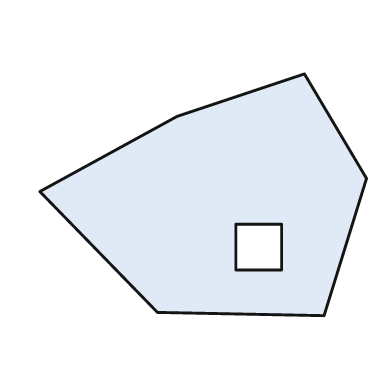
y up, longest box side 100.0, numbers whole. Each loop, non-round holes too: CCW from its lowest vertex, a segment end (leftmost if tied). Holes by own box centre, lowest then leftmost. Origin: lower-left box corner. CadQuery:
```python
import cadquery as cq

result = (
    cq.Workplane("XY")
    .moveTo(87.0, 0.0)
    .lineTo(100.0, 42.0)
    .lineTo(81.0, 74.0)
    .lineTo(42.0, 61.0)
    .lineTo(0.0, 38.0)
    .lineTo(36.0, 1.0)
    .close()
    .moveTo(60.0, 14.0)
    .lineTo(74.0, 14.0)
    .lineTo(74.0, 28.0)
    .lineTo(60.0, 28.0)
    .close()
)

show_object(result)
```